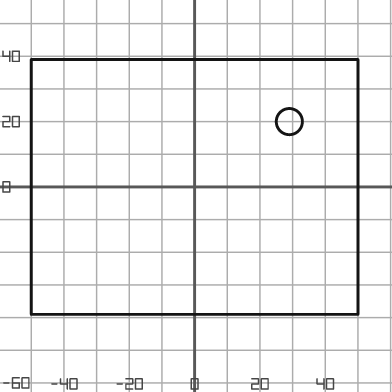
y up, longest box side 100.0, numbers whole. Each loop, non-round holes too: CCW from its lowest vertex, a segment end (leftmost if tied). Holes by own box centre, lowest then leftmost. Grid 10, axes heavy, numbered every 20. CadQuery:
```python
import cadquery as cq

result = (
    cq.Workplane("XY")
    .moveTo(-50.0, -39.0)
    .lineTo(50.0, -39.0)
    .lineTo(50.0, 39.0)
    .lineTo(-50.0, 39.0)
    .close()
    .moveTo(29.0, 20.0)
    .circle(4.0)
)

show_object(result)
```